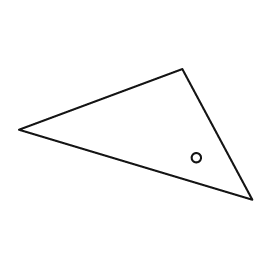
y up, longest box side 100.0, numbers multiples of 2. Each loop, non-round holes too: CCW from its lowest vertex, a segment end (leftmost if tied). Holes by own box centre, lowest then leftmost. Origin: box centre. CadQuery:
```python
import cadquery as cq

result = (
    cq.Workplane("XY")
    .moveTo(50.0, -28.0)
    .lineTo(20.0, 28.0)
    .lineTo(-50.0, 2.0)
    .close()
    .moveTo(26.0, -10.0)
    .circle(2.0)
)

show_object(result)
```